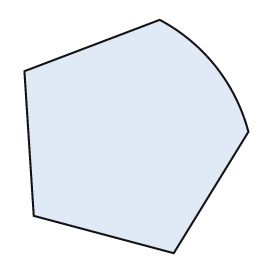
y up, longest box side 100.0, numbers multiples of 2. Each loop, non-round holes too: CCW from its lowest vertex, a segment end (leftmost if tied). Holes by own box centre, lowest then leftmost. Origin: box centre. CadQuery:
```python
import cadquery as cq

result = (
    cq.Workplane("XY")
    .moveTo(16.0, -50.0)
    .lineTo(48.0, 2.0)
    .threePointArc((34.0, 30.0), (10.0, 50.0))
    .lineTo(-48.0, 28.0)
    .lineTo(-44.0, -34.0)
    .close()
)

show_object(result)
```